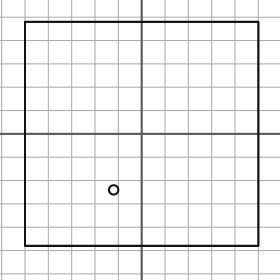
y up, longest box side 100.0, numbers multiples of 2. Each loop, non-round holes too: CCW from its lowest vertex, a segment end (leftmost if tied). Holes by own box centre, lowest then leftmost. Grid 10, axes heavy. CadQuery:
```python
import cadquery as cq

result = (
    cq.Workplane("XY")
    .moveTo(-50.0, -48.0)
    .lineTo(50.0, -48.0)
    .lineTo(50.0, 48.0)
    .lineTo(-50.0, 48.0)
    .close()
    .moveTo(-12.0, -24.0)
    .circle(2.0)
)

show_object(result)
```